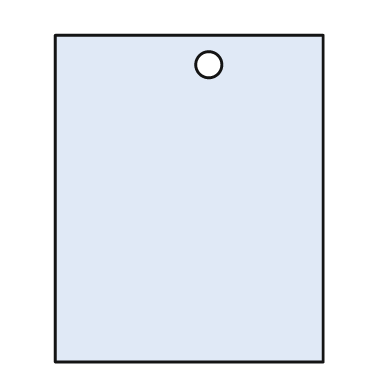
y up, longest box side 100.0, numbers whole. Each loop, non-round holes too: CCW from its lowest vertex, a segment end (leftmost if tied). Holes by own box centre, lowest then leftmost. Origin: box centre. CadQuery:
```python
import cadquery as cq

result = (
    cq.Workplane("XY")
    .moveTo(-41.0, -50.0)
    .lineTo(41.0, -50.0)
    .lineTo(41.0, 50.0)
    .lineTo(-41.0, 50.0)
    .close()
    .moveTo(6.0, 41.0)
    .circle(4.0)
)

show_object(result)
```